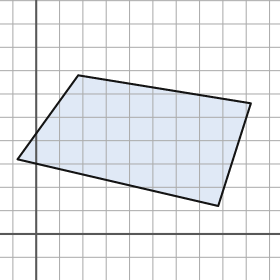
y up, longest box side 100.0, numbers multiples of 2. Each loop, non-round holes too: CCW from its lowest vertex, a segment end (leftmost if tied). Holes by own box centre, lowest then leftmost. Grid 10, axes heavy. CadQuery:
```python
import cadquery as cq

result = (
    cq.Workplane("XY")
    .moveTo(78.0, 12.0)
    .lineTo(92.0, 56.0)
    .lineTo(18.0, 68.0)
    .lineTo(-8.0, 32.0)
    .close()
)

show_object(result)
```